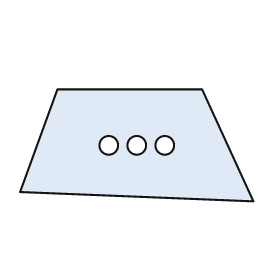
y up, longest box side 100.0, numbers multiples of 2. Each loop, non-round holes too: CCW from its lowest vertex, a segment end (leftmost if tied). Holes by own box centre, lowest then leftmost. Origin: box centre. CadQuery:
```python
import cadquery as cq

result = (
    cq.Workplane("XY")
    .moveTo(50.0, -24.0)
    .lineTo(28.0, 24.0)
    .lineTo(-34.0, 24.0)
    .lineTo(-50.0, -20.0)
    .close()
    .moveTo(-12.0, 0.0)
    .circle(4.0)
    .moveTo(0.0, 0.0)
    .circle(4.0)
    .moveTo(12.0, 0.0)
    .circle(4.0)
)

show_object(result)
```